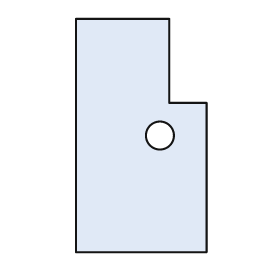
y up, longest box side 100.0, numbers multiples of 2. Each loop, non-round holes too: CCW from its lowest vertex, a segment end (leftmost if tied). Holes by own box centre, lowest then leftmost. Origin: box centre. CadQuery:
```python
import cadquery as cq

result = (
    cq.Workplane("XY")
    .moveTo(-28.0, -50.0)
    .lineTo(28.0, -50.0)
    .lineTo(28.0, 14.0)
    .lineTo(12.0, 14.0)
    .lineTo(12.0, 50.0)
    .lineTo(-28.0, 50.0)
    .close()
    .moveTo(8.0, 0.0)
    .circle(6.0)
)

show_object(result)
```